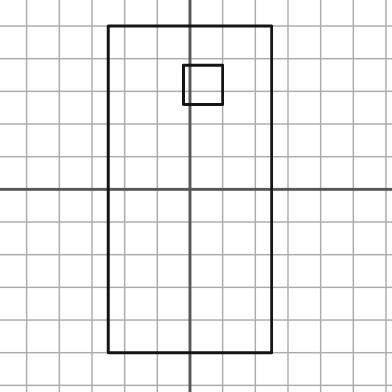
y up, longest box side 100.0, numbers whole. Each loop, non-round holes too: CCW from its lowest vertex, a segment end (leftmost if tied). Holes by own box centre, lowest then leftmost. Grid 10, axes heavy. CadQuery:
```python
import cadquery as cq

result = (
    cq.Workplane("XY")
    .moveTo(-25.0, -50.0)
    .lineTo(25.0, -50.0)
    .lineTo(25.0, 50.0)
    .lineTo(-25.0, 50.0)
    .close()
    .moveTo(-2.0, 26.0)
    .lineTo(10.0, 26.0)
    .lineTo(10.0, 38.0)
    .lineTo(-2.0, 38.0)
    .close()
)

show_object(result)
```